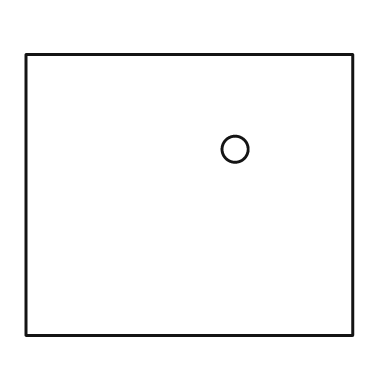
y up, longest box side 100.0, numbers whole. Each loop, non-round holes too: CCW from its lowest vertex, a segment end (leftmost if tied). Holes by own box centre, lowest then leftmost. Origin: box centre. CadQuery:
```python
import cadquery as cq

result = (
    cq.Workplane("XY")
    .moveTo(-50.0, -43.0)
    .lineTo(50.0, -43.0)
    .lineTo(50.0, 43.0)
    .lineTo(-50.0, 43.0)
    .close()
    .moveTo(14.0, 14.0)
    .circle(4.0)
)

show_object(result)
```